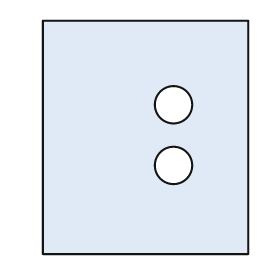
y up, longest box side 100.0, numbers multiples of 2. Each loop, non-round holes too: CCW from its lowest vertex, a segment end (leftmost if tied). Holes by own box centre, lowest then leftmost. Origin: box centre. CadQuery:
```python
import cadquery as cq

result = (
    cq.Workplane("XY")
    .moveTo(-44.0, -50.0)
    .lineTo(44.0, -50.0)
    .lineTo(44.0, 50.0)
    .lineTo(-44.0, 50.0)
    .close()
    .moveTo(12.0, -12.0)
    .circle(8.0)
    .moveTo(12.0, 14.0)
    .circle(8.0)
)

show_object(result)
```